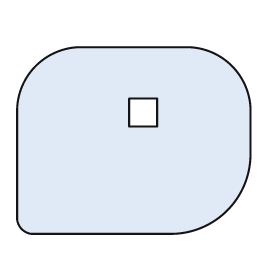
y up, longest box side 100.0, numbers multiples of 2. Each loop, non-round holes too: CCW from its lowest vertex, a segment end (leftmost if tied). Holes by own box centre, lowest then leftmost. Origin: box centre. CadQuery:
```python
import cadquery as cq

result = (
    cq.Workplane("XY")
    .moveTo(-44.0, -40.0)
    .lineTo(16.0, -40.0)
    .threePointArc((40.0, -30.0), (50.0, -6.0))
    .lineTo(50.0, 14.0)
    .threePointArc((42.0, 32.0), (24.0, 40.0))
    .lineTo(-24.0, 40.0)
    .threePointArc((-42.0, 32.0), (-50.0, 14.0))
    .lineTo(-50.0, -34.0)
    .threePointArc((-48.0, -38.0), (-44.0, -40.0))
    .close()
    .moveTo(-2.0, 6.0)
    .lineTo(10.0, 6.0)
    .lineTo(10.0, 18.0)
    .lineTo(-2.0, 18.0)
    .close()
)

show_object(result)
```